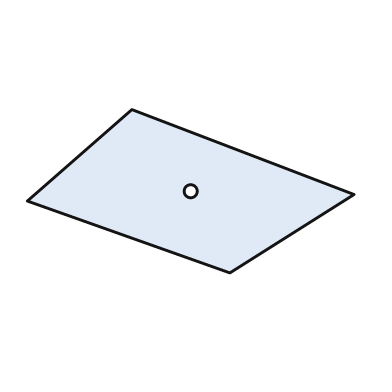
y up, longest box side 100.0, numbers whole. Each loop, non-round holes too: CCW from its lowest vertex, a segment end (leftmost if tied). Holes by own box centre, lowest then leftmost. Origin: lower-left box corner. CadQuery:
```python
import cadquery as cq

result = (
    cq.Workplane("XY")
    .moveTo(62.0, 0.0)
    .lineTo(100.0, 24.0)
    .lineTo(32.0, 50.0)
    .lineTo(0.0, 22.0)
    .close()
    .moveTo(50.0, 25.0)
    .circle(2.0)
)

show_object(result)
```